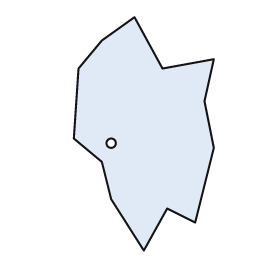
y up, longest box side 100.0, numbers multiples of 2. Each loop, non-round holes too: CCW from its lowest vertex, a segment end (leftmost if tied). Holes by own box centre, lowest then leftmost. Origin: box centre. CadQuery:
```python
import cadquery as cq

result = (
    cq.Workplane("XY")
    .moveTo(0.0, -50.0)
    .lineTo(10.0, -32.0)
    .lineTo(22.0, -38.0)
    .lineTo(30.0, -6.0)
    .lineTo(26.0, 14.0)
    .lineTo(30.0, 32.0)
    .lineTo(8.0, 28.0)
    .lineTo(-4.0, 50.0)
    .lineTo(-18.0, 40.0)
    .lineTo(-28.0, 28.0)
    .lineTo(-30.0, -2.0)
    .lineTo(-18.0, -12.0)
    .lineTo(-14.0, -28.0)
    .close()
    .moveTo(-14.0, -4.0)
    .circle(2.0)
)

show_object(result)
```